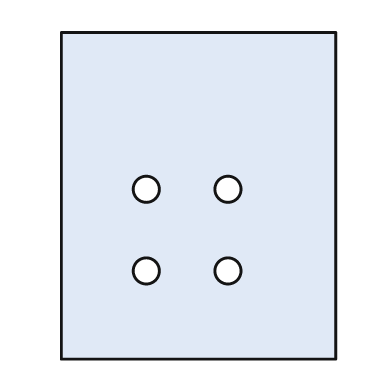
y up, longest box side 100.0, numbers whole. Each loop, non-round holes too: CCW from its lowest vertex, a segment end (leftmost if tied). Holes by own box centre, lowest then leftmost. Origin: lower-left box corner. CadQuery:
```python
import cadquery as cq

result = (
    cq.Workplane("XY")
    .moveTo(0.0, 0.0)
    .lineTo(84.0, 0.0)
    .lineTo(84.0, 100.0)
    .lineTo(0.0, 100.0)
    .close()
    .moveTo(26.0, 27.0)
    .circle(4.0)
    .moveTo(51.0, 27.0)
    .circle(4.0)
    .moveTo(26.0, 52.0)
    .circle(4.0)
    .moveTo(51.0, 52.0)
    .circle(4.0)
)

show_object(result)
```